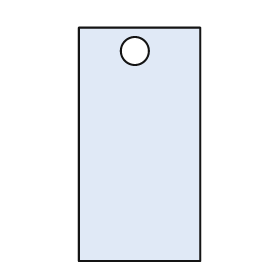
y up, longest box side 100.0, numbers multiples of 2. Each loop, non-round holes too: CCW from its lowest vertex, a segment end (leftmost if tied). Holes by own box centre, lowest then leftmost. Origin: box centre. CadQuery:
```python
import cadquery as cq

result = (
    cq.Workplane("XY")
    .moveTo(-26.0, -50.0)
    .lineTo(26.0, -50.0)
    .lineTo(26.0, 50.0)
    .lineTo(-26.0, 50.0)
    .close()
    .moveTo(-2.0, 40.0)
    .circle(6.0)
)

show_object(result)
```